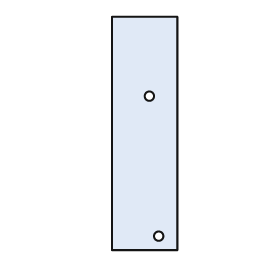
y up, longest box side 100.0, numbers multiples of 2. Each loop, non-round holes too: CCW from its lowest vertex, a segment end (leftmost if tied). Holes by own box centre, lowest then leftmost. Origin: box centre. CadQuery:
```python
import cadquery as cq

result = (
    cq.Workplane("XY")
    .moveTo(-14.0, -50.0)
    .lineTo(14.0, -50.0)
    .lineTo(14.0, 50.0)
    .lineTo(-14.0, 50.0)
    .close()
    .moveTo(6.0, -44.0)
    .circle(2.0)
    .moveTo(2.0, 16.0)
    .circle(2.0)
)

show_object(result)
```